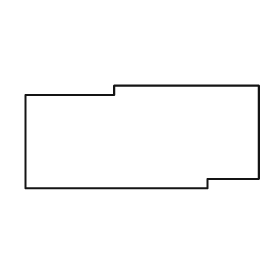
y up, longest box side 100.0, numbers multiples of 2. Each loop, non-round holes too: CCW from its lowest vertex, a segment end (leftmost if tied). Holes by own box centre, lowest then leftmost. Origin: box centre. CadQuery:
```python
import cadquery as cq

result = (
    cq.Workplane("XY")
    .moveTo(-50.0, -22.0)
    .lineTo(28.0, -22.0)
    .lineTo(28.0, -18.0)
    .lineTo(50.0, -18.0)
    .lineTo(50.0, 22.0)
    .lineTo(-12.0, 22.0)
    .lineTo(-12.0, 18.0)
    .lineTo(-50.0, 18.0)
    .close()
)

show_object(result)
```